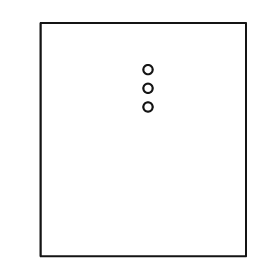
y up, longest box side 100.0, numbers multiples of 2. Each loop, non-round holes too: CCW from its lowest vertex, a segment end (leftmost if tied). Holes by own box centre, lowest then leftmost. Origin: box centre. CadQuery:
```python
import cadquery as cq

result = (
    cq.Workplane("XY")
    .moveTo(-44.0, -50.0)
    .lineTo(44.0, -50.0)
    .lineTo(44.0, 50.0)
    .lineTo(-44.0, 50.0)
    .close()
    .moveTo(2.0, 14.0)
    .circle(2.0)
    .moveTo(2.0, 22.0)
    .circle(2.0)
    .moveTo(2.0, 30.0)
    .circle(2.0)
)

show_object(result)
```